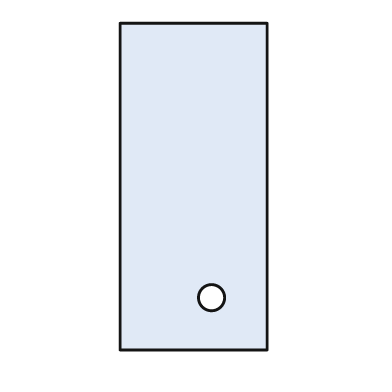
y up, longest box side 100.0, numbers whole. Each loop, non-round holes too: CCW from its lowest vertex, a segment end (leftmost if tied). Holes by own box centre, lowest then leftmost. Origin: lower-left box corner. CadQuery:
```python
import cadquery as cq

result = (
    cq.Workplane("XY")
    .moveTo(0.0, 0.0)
    .lineTo(45.0, 0.0)
    .lineTo(45.0, 100.0)
    .lineTo(0.0, 100.0)
    .close()
    .moveTo(28.0, 16.0)
    .circle(4.0)
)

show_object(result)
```